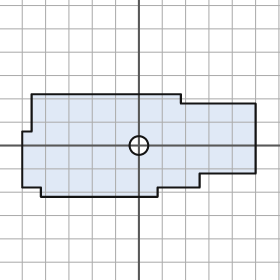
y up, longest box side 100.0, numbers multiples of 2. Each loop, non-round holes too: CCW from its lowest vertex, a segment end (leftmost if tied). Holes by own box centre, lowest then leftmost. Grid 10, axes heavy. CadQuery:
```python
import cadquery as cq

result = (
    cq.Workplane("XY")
    .moveTo(-42.0, -22.0)
    .lineTo(8.0, -22.0)
    .lineTo(8.0, -18.0)
    .lineTo(26.0, -18.0)
    .lineTo(26.0, -12.0)
    .lineTo(50.0, -12.0)
    .lineTo(50.0, 18.0)
    .lineTo(18.0, 18.0)
    .lineTo(18.0, 22.0)
    .lineTo(-46.0, 22.0)
    .lineTo(-46.0, 6.0)
    .lineTo(-50.0, 6.0)
    .lineTo(-50.0, -18.0)
    .lineTo(-42.0, -18.0)
    .close()
    .moveTo(0.0, 0.0)
    .circle(4.0)
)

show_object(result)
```